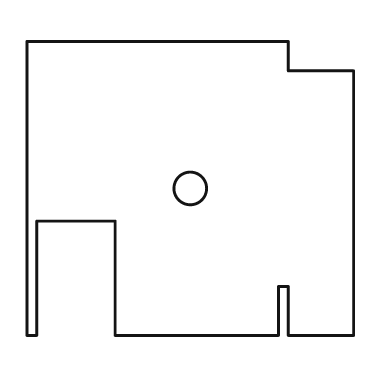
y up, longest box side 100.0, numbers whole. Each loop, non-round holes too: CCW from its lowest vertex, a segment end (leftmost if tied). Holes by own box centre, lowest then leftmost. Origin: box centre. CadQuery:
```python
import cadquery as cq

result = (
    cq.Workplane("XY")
    .moveTo(-50.0, -45.0)
    .lineTo(-47.0, -45.0)
    .lineTo(-47.0, -10.0)
    .lineTo(-23.0, -10.0)
    .lineTo(-23.0, -45.0)
    .lineTo(27.0, -45.0)
    .lineTo(27.0, -30.0)
    .lineTo(30.0, -30.0)
    .lineTo(30.0, -45.0)
    .lineTo(50.0, -45.0)
    .lineTo(50.0, 36.0)
    .lineTo(30.0, 36.0)
    .lineTo(30.0, 45.0)
    .lineTo(-50.0, 45.0)
    .close()
    .moveTo(0.0, 0.0)
    .circle(5.0)
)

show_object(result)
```